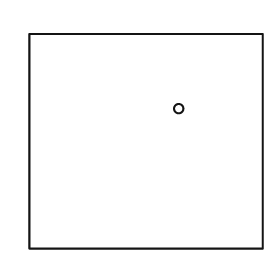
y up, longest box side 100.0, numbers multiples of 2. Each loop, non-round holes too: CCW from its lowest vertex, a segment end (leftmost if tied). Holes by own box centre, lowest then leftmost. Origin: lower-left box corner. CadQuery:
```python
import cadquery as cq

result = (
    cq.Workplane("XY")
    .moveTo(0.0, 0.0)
    .lineTo(100.0, 0.0)
    .lineTo(100.0, 92.0)
    .lineTo(0.0, 92.0)
    .close()
    .moveTo(64.0, 60.0)
    .circle(2.0)
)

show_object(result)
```